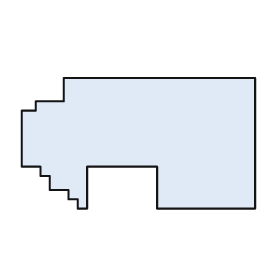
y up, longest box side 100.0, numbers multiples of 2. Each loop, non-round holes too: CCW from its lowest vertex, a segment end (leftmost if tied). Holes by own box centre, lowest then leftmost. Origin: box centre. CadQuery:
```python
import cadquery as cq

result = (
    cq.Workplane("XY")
    .moveTo(-26.0, -28.0)
    .lineTo(-22.0, -28.0)
    .lineTo(-22.0, -10.0)
    .lineTo(8.0, -10.0)
    .lineTo(8.0, -28.0)
    .lineTo(50.0, -28.0)
    .lineTo(50.0, 28.0)
    .lineTo(-32.0, 28.0)
    .lineTo(-32.0, 18.0)
    .lineTo(-44.0, 18.0)
    .lineTo(-44.0, 14.0)
    .lineTo(-50.0, 14.0)
    .lineTo(-50.0, -10.0)
    .lineTo(-42.0, -10.0)
    .lineTo(-42.0, -14.0)
    .lineTo(-38.0, -14.0)
    .lineTo(-38.0, -20.0)
    .lineTo(-30.0, -20.0)
    .lineTo(-30.0, -24.0)
    .lineTo(-26.0, -24.0)
    .close()
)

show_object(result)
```